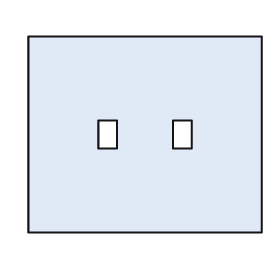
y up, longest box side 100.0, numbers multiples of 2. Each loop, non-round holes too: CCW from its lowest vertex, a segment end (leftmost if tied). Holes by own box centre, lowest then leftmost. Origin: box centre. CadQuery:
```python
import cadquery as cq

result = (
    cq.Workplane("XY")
    .moveTo(-50.0, -42.0)
    .lineTo(50.0, -42.0)
    .lineTo(50.0, 42.0)
    .lineTo(-50.0, 42.0)
    .close()
    .moveTo(-20.0, -6.0)
    .lineTo(-12.0, -6.0)
    .lineTo(-12.0, 6.0)
    .lineTo(-20.0, 6.0)
    .close()
    .moveTo(12.0, -6.0)
    .lineTo(20.0, -6.0)
    .lineTo(20.0, 6.0)
    .lineTo(12.0, 6.0)
    .close()
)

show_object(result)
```